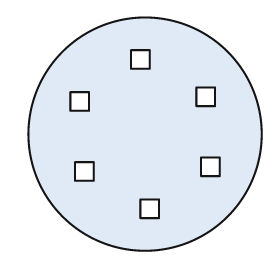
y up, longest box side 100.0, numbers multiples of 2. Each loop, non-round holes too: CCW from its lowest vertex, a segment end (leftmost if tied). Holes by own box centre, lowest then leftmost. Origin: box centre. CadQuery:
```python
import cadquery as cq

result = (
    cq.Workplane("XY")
    .moveTo(0.0, 0.0)
    .circle(50.0)
    .moveTo(-2.0, -36.0)
    .lineTo(6.0, -36.0)
    .lineTo(6.0, -28.0)
    .lineTo(-2.0, -28.0)
    .close()
    .moveTo(-30.0, -20.0)
    .lineTo(-22.0, -20.0)
    .lineTo(-22.0, -12.0)
    .lineTo(-30.0, -12.0)
    .close()
    .moveTo(24.0, -18.0)
    .lineTo(32.0, -18.0)
    .lineTo(32.0, -10.0)
    .lineTo(24.0, -10.0)
    .close()
    .moveTo(-32.0, 10.0)
    .lineTo(-24.0, 10.0)
    .lineTo(-24.0, 18.0)
    .lineTo(-32.0, 18.0)
    .close()
    .moveTo(22.0, 12.0)
    .lineTo(30.0, 12.0)
    .lineTo(30.0, 20.0)
    .lineTo(22.0, 20.0)
    .close()
    .moveTo(-6.0, 28.0)
    .lineTo(2.0, 28.0)
    .lineTo(2.0, 36.0)
    .lineTo(-6.0, 36.0)
    .close()
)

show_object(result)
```